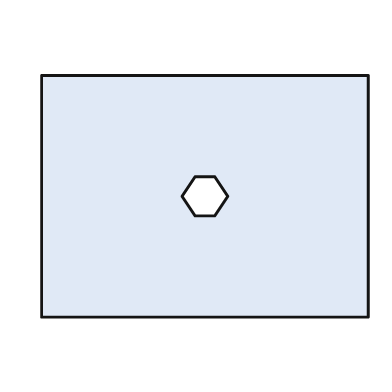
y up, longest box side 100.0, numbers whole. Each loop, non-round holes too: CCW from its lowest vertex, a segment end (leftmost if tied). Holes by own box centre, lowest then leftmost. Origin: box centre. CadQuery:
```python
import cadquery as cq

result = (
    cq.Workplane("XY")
    .moveTo(-50.0, -37.0)
    .lineTo(50.0, -37.0)
    .lineTo(50.0, 37.0)
    .lineTo(-50.0, 37.0)
    .close()
    .moveTo(-3.0, -6.0)
    .lineTo(3.0, -6.0)
    .lineTo(7.0, 0.0)
    .lineTo(3.0, 6.0)
    .lineTo(-3.0, 6.0)
    .lineTo(-7.0, 0.0)
    .close()
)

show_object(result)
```